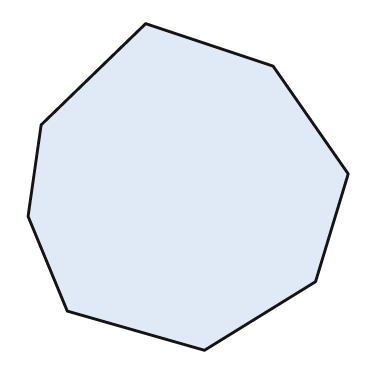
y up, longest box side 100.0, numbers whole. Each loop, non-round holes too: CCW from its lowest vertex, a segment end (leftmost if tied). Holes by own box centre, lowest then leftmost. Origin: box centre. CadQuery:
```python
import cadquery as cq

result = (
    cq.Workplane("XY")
    .moveTo(5.0, -50.0)
    .lineTo(39.0, -29.0)
    .lineTo(49.0, 4.0)
    .lineTo(26.0, 37.0)
    .lineTo(-13.0, 50.0)
    .lineTo(-45.0, 19.0)
    .lineTo(-49.0, -9.0)
    .lineTo(-37.0, -38.0)
    .close()
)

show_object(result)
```